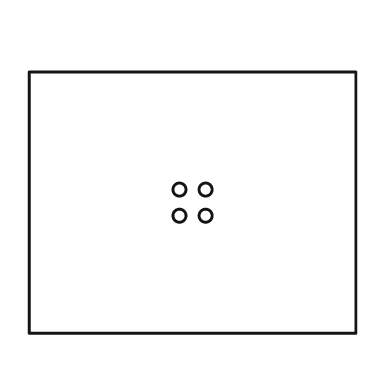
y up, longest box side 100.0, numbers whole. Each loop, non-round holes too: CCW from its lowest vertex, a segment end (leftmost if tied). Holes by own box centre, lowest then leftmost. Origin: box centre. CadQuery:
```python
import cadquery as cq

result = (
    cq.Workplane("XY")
    .moveTo(-50.0, -40.0)
    .lineTo(50.0, -40.0)
    .lineTo(50.0, 40.0)
    .lineTo(-50.0, 40.0)
    .close()
    .moveTo(-4.0, -4.0)
    .circle(2.0)
    .moveTo(4.0, -4.0)
    .circle(2.0)
    .moveTo(-4.0, 4.0)
    .circle(2.0)
    .moveTo(4.0, 4.0)
    .circle(2.0)
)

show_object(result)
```